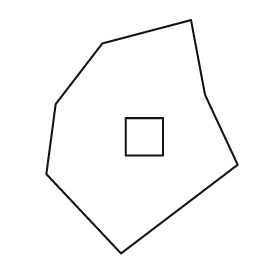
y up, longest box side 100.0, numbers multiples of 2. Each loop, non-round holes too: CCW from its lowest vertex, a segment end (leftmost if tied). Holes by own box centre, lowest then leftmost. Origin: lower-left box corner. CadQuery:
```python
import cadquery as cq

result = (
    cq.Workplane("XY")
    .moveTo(32.0, 0.0)
    .lineTo(82.0, 38.0)
    .lineTo(68.0, 68.0)
    .lineTo(62.0, 100.0)
    .lineTo(24.0, 90.0)
    .lineTo(4.0, 64.0)
    .lineTo(0.0, 34.0)
    .close()
    .moveTo(34.0, 42.0)
    .lineTo(50.0, 42.0)
    .lineTo(50.0, 58.0)
    .lineTo(34.0, 58.0)
    .close()
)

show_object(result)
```